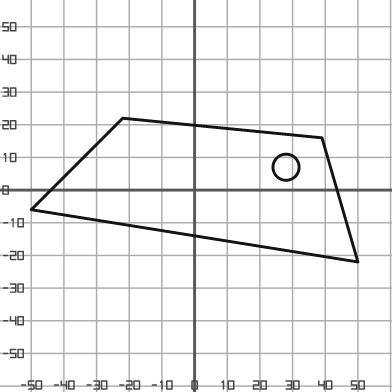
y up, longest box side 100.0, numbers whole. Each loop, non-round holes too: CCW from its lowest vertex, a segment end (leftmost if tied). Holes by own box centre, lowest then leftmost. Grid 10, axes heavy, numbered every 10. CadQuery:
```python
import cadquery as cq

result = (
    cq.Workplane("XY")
    .moveTo(50.0, -22.0)
    .lineTo(39.0, 16.0)
    .lineTo(-22.0, 22.0)
    .lineTo(-50.0, -6.0)
    .close()
    .moveTo(28.0, 7.0)
    .circle(4.0)
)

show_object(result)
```